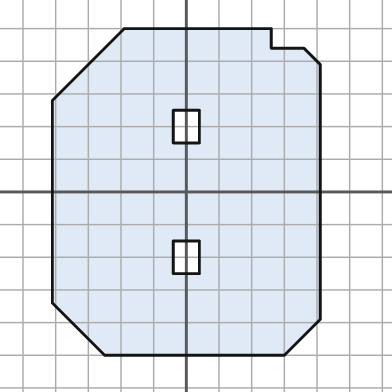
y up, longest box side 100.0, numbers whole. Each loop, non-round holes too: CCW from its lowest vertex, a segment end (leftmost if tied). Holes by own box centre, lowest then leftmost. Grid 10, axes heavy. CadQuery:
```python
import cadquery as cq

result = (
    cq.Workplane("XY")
    .moveTo(-25.0, -50.0)
    .lineTo(30.0, -50.0)
    .lineTo(41.0, -39.0)
    .lineTo(41.0, 39.0)
    .lineTo(36.0, 44.0)
    .lineTo(26.0, 44.0)
    .lineTo(26.0, 50.0)
    .lineTo(-19.0, 50.0)
    .lineTo(-41.0, 28.0)
    .lineTo(-41.0, -34.0)
    .close()
    .moveTo(-4.0, -25.0)
    .lineTo(4.0, -25.0)
    .lineTo(4.0, -15.0)
    .lineTo(-4.0, -15.0)
    .close()
    .moveTo(-4.0, 15.0)
    .lineTo(4.0, 15.0)
    .lineTo(4.0, 25.0)
    .lineTo(-4.0, 25.0)
    .close()
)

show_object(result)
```